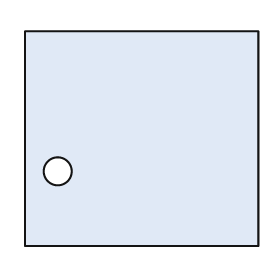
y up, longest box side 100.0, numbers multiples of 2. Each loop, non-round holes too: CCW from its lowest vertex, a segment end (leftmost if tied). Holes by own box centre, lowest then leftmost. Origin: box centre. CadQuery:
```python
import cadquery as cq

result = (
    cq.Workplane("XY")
    .moveTo(-50.0, -46.0)
    .lineTo(50.0, -46.0)
    .lineTo(50.0, 46.0)
    .lineTo(-50.0, 46.0)
    .close()
    .moveTo(-36.0, -14.0)
    .circle(6.0)
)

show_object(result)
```